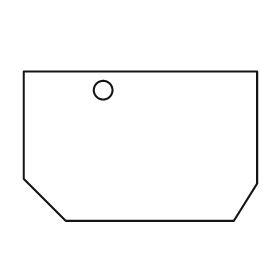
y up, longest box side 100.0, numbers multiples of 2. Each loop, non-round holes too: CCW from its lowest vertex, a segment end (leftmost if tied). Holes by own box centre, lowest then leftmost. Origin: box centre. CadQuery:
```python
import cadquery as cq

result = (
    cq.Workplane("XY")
    .moveTo(-32.0, -32.0)
    .lineTo(40.0, -32.0)
    .lineTo(50.0, -16.0)
    .lineTo(50.0, 32.0)
    .lineTo(-50.0, 32.0)
    .lineTo(-50.0, -14.0)
    .close()
    .moveTo(-16.0, 24.0)
    .circle(4.0)
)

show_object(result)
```